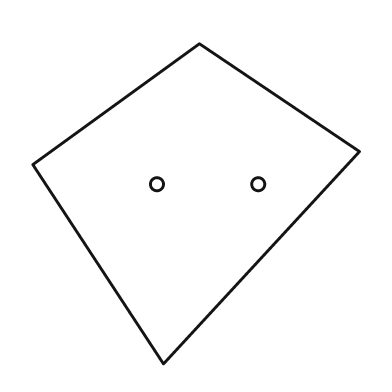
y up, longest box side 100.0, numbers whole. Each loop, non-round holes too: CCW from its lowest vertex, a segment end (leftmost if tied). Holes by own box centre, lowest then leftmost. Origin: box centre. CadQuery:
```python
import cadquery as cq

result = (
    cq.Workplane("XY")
    .moveTo(-10.0, -49.0)
    .lineTo(50.0, 16.0)
    .lineTo(1.0, 49.0)
    .lineTo(-50.0, 12.0)
    .close()
    .moveTo(-12.0, 6.0)
    .circle(2.0)
    .moveTo(19.0, 6.0)
    .circle(2.0)
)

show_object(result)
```